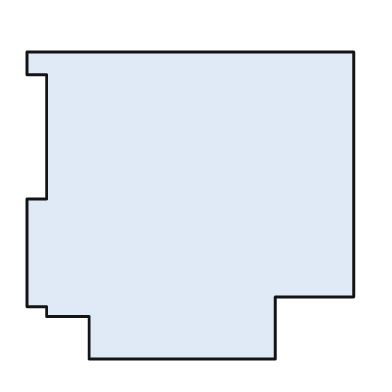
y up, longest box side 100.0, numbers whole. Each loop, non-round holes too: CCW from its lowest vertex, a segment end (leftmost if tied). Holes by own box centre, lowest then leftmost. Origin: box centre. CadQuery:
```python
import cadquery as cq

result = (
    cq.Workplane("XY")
    .moveTo(-31.0, -47.0)
    .lineTo(26.0, -47.0)
    .lineTo(26.0, -28.0)
    .lineTo(50.0, -28.0)
    .lineTo(50.0, 47.0)
    .lineTo(-50.0, 47.0)
    .lineTo(-50.0, 40.0)
    .lineTo(-44.0, 40.0)
    .lineTo(-44.0, 2.0)
    .lineTo(-50.0, 2.0)
    .lineTo(-50.0, -31.0)
    .lineTo(-44.0, -31.0)
    .lineTo(-44.0, -34.0)
    .lineTo(-31.0, -34.0)
    .close()
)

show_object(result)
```